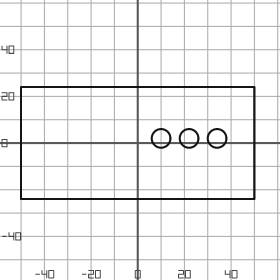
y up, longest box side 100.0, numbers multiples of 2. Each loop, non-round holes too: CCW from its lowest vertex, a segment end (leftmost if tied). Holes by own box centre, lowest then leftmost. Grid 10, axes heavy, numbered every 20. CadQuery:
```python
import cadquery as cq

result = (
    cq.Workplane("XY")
    .moveTo(-50.0, -24.0)
    .lineTo(50.0, -24.0)
    .lineTo(50.0, 24.0)
    .lineTo(-50.0, 24.0)
    .close()
    .moveTo(10.0, 2.0)
    .circle(4.0)
    .moveTo(22.0, 2.0)
    .circle(4.0)
    .moveTo(34.0, 2.0)
    .circle(4.0)
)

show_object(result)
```